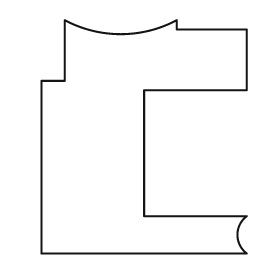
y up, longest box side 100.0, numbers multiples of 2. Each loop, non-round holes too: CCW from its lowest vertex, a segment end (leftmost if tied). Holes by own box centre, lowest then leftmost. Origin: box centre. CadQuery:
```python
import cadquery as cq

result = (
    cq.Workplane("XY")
    .moveTo(-44.0, -50.0)
    .lineTo(44.0, -50.0)
    .threePointArc((40.0, -42.0), (44.0, -34.0))
    .lineTo(0.0, -34.0)
    .lineTo(0.0, 20.0)
    .lineTo(44.0, 20.0)
    .lineTo(44.0, 46.0)
    .lineTo(14.0, 46.0)
    .lineTo(14.0, 50.0)
    .threePointArc((-10.0, 44.0), (-34.0, 50.0))
    .lineTo(-34.0, 24.0)
    .lineTo(-44.0, 24.0)
    .close()
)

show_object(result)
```